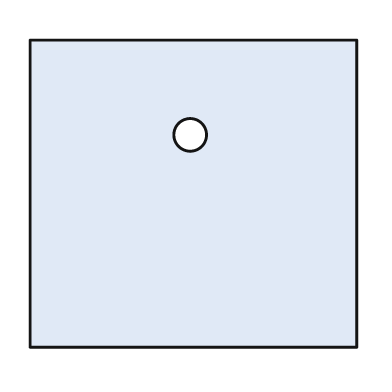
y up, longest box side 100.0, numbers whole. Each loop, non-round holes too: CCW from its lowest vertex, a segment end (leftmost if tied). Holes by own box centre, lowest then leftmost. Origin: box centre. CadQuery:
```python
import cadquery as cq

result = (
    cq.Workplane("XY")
    .moveTo(-50.0, -47.0)
    .lineTo(50.0, -47.0)
    .lineTo(50.0, 47.0)
    .lineTo(-50.0, 47.0)
    .close()
    .moveTo(-1.0, 18.0)
    .circle(5.0)
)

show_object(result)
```